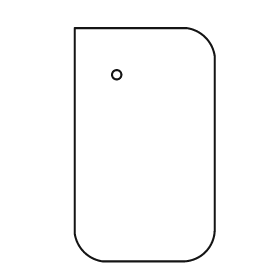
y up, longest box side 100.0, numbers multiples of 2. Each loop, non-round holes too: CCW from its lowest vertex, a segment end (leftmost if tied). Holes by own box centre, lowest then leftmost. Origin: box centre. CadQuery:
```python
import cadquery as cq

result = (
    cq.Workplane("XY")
    .moveTo(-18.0, -50.0)
    .lineTo(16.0, -50.0)
    .threePointArc((26.0, -46.0), (30.0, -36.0))
    .lineTo(30.0, 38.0)
    .threePointArc((26.0, 46.0), (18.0, 50.0))
    .lineTo(-30.0, 50.0)
    .lineTo(-30.0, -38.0)
    .threePointArc((-26.0, -46.0), (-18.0, -50.0))
    .close()
    .moveTo(-12.0, 30.0)
    .circle(2.0)
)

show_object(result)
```